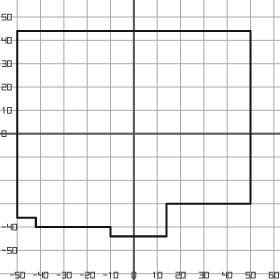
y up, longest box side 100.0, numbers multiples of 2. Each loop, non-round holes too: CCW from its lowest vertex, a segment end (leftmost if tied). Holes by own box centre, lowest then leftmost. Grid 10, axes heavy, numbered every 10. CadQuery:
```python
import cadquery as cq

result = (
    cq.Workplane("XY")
    .moveTo(-10.0, -44.0)
    .lineTo(14.0, -44.0)
    .lineTo(14.0, -30.0)
    .lineTo(50.0, -30.0)
    .lineTo(50.0, 44.0)
    .lineTo(-50.0, 44.0)
    .lineTo(-50.0, -36.0)
    .lineTo(-42.0, -36.0)
    .lineTo(-42.0, -40.0)
    .lineTo(-10.0, -40.0)
    .close()
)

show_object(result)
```